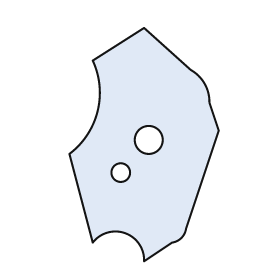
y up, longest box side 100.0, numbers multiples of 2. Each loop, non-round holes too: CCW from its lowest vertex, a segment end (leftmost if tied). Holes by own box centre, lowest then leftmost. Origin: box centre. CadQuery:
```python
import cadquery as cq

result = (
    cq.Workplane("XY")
    .moveTo(0.0, -50.0)
    .lineTo(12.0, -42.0)
    .threePointArc((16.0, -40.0), (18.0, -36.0))
    .lineTo(32.0, 6.0)
    .lineTo(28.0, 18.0)
    .threePointArc((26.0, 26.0), (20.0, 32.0))
    .lineTo(0.0, 50.0)
    .lineTo(-22.0, 36.0)
    .threePointArc((-20.0, 14.0), (-32.0, -4.0))
    .lineTo(-22.0, -42.0)
    .threePointArc((-8.0, -38.0), (0.0, -50.0))
    .close()
    .moveTo(-10.0, -12.0)
    .circle(4.0)
    .moveTo(2.0, 2.0)
    .circle(6.0)
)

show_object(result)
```